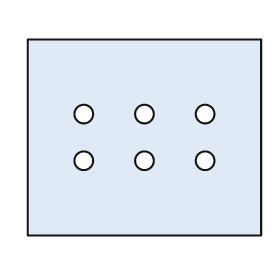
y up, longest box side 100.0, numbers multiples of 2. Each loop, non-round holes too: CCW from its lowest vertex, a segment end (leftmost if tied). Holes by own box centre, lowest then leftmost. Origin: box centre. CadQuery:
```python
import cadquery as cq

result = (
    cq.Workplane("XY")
    .moveTo(-50.0, -42.0)
    .lineTo(50.0, -42.0)
    .lineTo(50.0, 42.0)
    .lineTo(-50.0, 42.0)
    .close()
    .moveTo(-26.0, -10.0)
    .circle(4.0)
    .moveTo(0.0, -10.0)
    .circle(4.0)
    .moveTo(26.0, -10.0)
    .circle(4.0)
    .moveTo(-26.0, 10.0)
    .circle(4.0)
    .moveTo(0.0, 10.0)
    .circle(4.0)
    .moveTo(26.0, 10.0)
    .circle(4.0)
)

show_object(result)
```